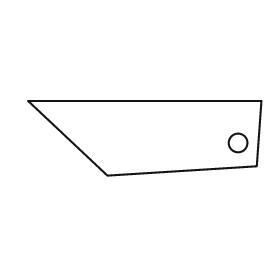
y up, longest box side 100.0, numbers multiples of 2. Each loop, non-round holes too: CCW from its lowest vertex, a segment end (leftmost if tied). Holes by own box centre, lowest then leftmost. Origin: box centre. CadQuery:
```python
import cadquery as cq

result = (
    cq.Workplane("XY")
    .moveTo(-16.0, -16.0)
    .lineTo(48.0, -12.0)
    .lineTo(50.0, 16.0)
    .lineTo(-50.0, 16.0)
    .close()
    .moveTo(40.0, -2.0)
    .circle(4.0)
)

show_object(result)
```